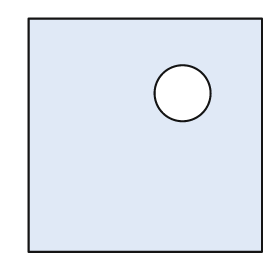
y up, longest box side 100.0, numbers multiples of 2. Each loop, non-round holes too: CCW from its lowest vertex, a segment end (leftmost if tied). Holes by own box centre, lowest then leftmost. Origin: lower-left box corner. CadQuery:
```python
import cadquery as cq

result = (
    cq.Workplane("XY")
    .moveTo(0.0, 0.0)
    .lineTo(100.0, 0.0)
    .lineTo(100.0, 100.0)
    .lineTo(0.0, 100.0)
    .close()
    .moveTo(66.0, 68.0)
    .circle(12.0)
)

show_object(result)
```